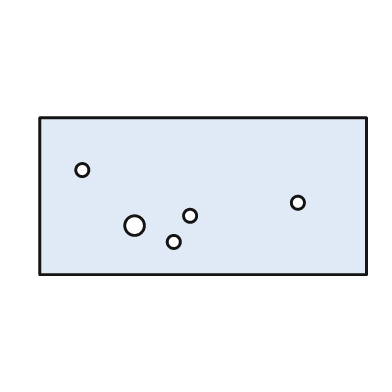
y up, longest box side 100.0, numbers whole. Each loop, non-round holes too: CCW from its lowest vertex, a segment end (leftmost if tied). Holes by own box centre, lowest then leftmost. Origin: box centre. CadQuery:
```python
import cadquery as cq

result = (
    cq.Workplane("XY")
    .moveTo(-50.0, -24.0)
    .lineTo(50.0, -24.0)
    .lineTo(50.0, 24.0)
    .lineTo(-50.0, 24.0)
    .close()
    .moveTo(-9.0, -14.0)
    .circle(2.0)
    .moveTo(-21.0, -9.0)
    .circle(3.0)
    .moveTo(-4.0, -6.0)
    .circle(2.0)
    .moveTo(29.0, -2.0)
    .circle(2.0)
    .moveTo(-37.0, 8.0)
    .circle(2.0)
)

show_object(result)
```